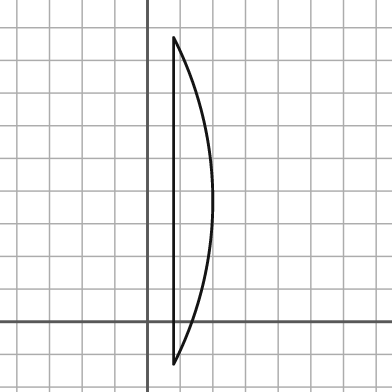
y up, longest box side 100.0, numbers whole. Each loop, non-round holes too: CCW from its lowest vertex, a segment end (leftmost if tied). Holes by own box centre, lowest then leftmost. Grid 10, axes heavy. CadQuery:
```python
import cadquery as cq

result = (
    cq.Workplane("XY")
    .moveTo(8.0, -13.0)
    .threePointArc((20.0, 37.0), (8.0, 87.0))
    .close()
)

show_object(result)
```